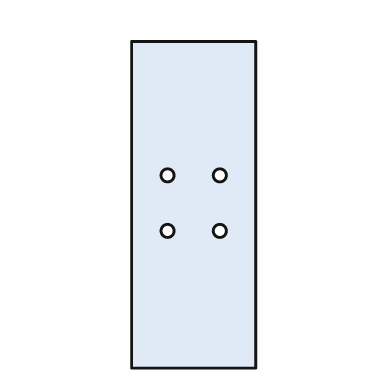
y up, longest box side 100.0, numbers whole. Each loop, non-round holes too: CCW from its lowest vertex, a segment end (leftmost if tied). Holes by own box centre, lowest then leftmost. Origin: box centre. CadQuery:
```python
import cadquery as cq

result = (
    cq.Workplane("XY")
    .moveTo(-19.0, -50.0)
    .lineTo(19.0, -50.0)
    .lineTo(19.0, 50.0)
    .lineTo(-19.0, 50.0)
    .close()
    .moveTo(-8.0, -8.0)
    .circle(2.0)
    .moveTo(8.0, -8.0)
    .circle(2.0)
    .moveTo(-8.0, 9.0)
    .circle(2.0)
    .moveTo(8.0, 9.0)
    .circle(2.0)
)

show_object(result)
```